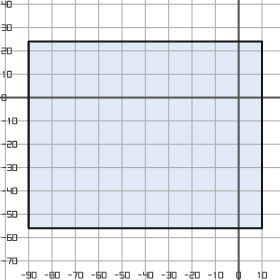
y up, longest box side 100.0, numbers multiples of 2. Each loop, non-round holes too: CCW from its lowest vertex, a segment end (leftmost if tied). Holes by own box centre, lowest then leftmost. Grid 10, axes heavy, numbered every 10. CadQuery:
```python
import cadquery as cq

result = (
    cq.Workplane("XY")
    .moveTo(-90.0, -56.0)
    .lineTo(10.0, -56.0)
    .lineTo(10.0, 24.0)
    .lineTo(-90.0, 24.0)
    .close()
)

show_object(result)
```